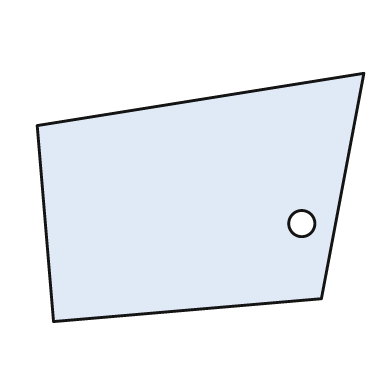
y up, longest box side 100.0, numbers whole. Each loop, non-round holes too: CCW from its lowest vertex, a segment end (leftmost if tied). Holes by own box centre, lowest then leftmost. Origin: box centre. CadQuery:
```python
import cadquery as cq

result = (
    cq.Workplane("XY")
    .moveTo(-45.0, -38.0)
    .lineTo(37.0, -31.0)
    .lineTo(50.0, 38.0)
    .lineTo(-50.0, 22.0)
    .close()
    .moveTo(31.0, -8.0)
    .circle(4.0)
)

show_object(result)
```